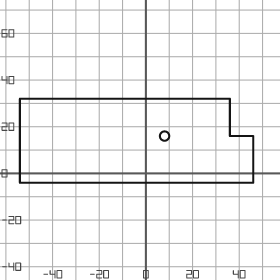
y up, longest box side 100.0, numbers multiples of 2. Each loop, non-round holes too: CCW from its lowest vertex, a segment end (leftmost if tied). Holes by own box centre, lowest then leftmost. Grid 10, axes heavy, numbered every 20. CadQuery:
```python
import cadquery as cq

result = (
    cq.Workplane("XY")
    .moveTo(-54.0, -4.0)
    .lineTo(46.0, -4.0)
    .lineTo(46.0, 16.0)
    .lineTo(36.0, 16.0)
    .lineTo(36.0, 32.0)
    .lineTo(-54.0, 32.0)
    .close()
    .moveTo(8.0, 16.0)
    .circle(2.0)
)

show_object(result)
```